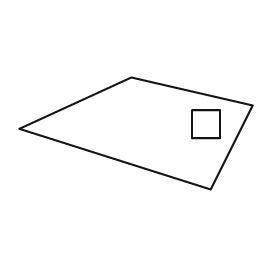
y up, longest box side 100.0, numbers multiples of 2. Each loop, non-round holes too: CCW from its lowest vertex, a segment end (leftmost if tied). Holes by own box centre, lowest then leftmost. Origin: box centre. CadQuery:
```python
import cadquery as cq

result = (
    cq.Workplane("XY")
    .moveTo(32.0, -24.0)
    .lineTo(50.0, 12.0)
    .lineTo(-2.0, 24.0)
    .lineTo(-50.0, 2.0)
    .close()
    .moveTo(24.0, -2.0)
    .lineTo(36.0, -2.0)
    .lineTo(36.0, 10.0)
    .lineTo(24.0, 10.0)
    .close()
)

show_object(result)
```